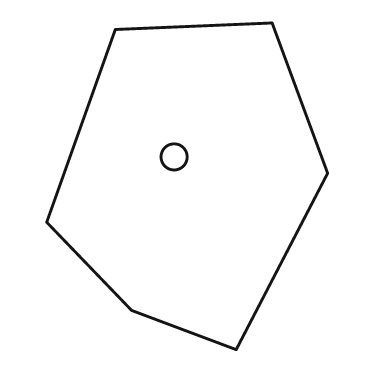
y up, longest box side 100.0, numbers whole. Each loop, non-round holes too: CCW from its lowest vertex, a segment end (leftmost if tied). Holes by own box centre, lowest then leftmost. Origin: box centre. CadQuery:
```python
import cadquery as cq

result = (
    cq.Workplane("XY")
    .moveTo(15.0, -50.0)
    .lineTo(43.0, 4.0)
    .lineTo(26.0, 50.0)
    .lineTo(-22.0, 48.0)
    .lineTo(-43.0, -11.0)
    .lineTo(-17.0, -38.0)
    .close()
    .moveTo(-4.0, 9.0)
    .circle(4.0)
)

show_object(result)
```